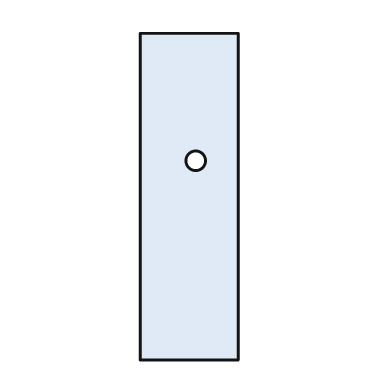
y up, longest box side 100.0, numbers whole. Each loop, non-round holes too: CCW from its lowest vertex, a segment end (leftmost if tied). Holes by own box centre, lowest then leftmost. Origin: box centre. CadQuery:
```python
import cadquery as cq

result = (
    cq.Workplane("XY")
    .moveTo(-15.0, -50.0)
    .lineTo(15.0, -50.0)
    .lineTo(15.0, 50.0)
    .lineTo(-15.0, 50.0)
    .close()
    .moveTo(2.0, 11.0)
    .circle(3.0)
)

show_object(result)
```